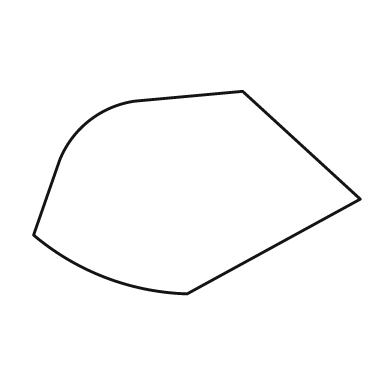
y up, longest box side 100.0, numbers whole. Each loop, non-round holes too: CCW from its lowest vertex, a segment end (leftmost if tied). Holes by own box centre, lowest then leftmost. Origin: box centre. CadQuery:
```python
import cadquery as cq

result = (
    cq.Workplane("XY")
    .moveTo(-3.0, -31.0)
    .lineTo(50.0, -2.0)
    .lineTo(14.0, 31.0)
    .lineTo(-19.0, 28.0)
    .threePointArc((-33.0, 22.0), (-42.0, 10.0))
    .lineTo(-50.0, -13.0)
    .threePointArc((-28.0, -26.0), (-3.0, -31.0))
    .close()
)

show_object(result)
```